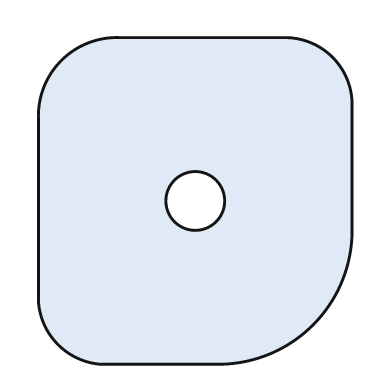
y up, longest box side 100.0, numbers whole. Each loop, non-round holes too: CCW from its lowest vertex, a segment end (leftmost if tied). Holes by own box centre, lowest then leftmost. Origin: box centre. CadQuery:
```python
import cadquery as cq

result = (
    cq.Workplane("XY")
    .moveTo(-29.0, -50.0)
    .lineTo(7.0, -50.0)
    .threePointArc((36.0, -38.0), (48.0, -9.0))
    .lineTo(48.0, 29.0)
    .threePointArc((42.0, 44.0), (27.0, 50.0))
    .lineTo(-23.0, 50.0)
    .threePointArc((-41.0, 43.0), (-48.0, 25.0))
    .lineTo(-48.0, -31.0)
    .threePointArc((-42.0, -44.0), (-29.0, -50.0))
    .close()
    .moveTo(0.0, 0.0)
    .circle(9.0)
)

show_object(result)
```